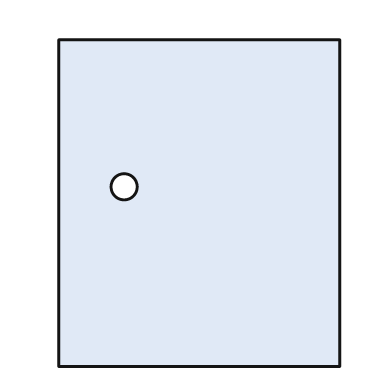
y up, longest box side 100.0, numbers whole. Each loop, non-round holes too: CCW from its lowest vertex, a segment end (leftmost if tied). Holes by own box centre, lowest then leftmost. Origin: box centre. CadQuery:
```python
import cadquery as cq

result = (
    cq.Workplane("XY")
    .moveTo(-43.0, -50.0)
    .lineTo(43.0, -50.0)
    .lineTo(43.0, 50.0)
    .lineTo(-43.0, 50.0)
    .close()
    .moveTo(-23.0, 5.0)
    .circle(4.0)
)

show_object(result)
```